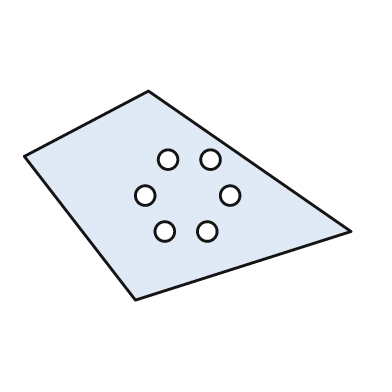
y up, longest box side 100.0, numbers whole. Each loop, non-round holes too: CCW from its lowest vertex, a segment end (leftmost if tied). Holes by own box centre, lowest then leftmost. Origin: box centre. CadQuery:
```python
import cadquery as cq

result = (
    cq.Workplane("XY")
    .moveTo(-16.0, -32.0)
    .lineTo(50.0, -11.0)
    .lineTo(-12.0, 32.0)
    .lineTo(-50.0, 12.0)
    .close()
    .moveTo(-7.0, -11.0)
    .circle(3.0)
    .moveTo(6.0, -11.0)
    .circle(3.0)
    .moveTo(-13.0, 0.0)
    .circle(3.0)
    .moveTo(13.0, 0.0)
    .circle(3.0)
    .moveTo(-6.0, 11.0)
    .circle(3.0)
    .moveTo(7.0, 11.0)
    .circle(3.0)
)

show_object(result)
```